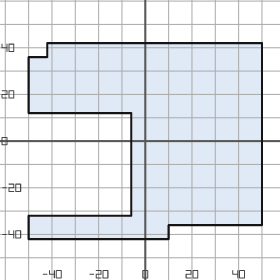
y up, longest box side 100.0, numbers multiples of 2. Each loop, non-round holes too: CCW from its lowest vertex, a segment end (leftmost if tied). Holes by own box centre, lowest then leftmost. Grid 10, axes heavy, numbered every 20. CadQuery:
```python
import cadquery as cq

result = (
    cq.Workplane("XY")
    .moveTo(-50.0, -42.0)
    .lineTo(10.0, -42.0)
    .lineTo(10.0, -36.0)
    .lineTo(50.0, -36.0)
    .lineTo(50.0, 42.0)
    .lineTo(-42.0, 42.0)
    .lineTo(-42.0, 36.0)
    .lineTo(-50.0, 36.0)
    .lineTo(-50.0, 12.0)
    .lineTo(-6.0, 12.0)
    .lineTo(-6.0, -32.0)
    .lineTo(-50.0, -32.0)
    .close()
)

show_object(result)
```